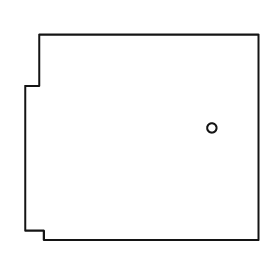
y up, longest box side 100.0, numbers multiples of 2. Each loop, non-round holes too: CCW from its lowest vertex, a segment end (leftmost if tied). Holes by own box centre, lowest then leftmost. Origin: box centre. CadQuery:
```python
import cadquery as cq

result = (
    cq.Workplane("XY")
    .moveTo(-42.0, -44.0)
    .lineTo(50.0, -44.0)
    .lineTo(50.0, 44.0)
    .lineTo(-44.0, 44.0)
    .lineTo(-44.0, 22.0)
    .lineTo(-50.0, 22.0)
    .lineTo(-50.0, -40.0)
    .lineTo(-42.0, -40.0)
    .close()
    .moveTo(30.0, 4.0)
    .circle(2.0)
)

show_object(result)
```